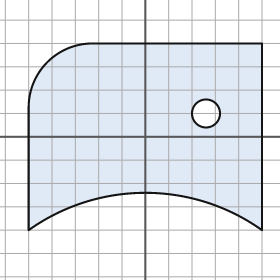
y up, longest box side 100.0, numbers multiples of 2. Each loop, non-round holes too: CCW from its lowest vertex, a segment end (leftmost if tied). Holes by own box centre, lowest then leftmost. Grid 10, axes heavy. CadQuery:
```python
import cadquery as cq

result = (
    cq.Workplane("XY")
    .moveTo(-50.0, -40.0)
    .threePointArc((0.0, -24.0), (50.0, -40.0))
    .lineTo(50.0, 40.0)
    .lineTo(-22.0, 40.0)
    .threePointArc((-42.0, 32.0), (-50.0, 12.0))
    .close()
    .moveTo(26.0, 10.0)
    .circle(6.0)
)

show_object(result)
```